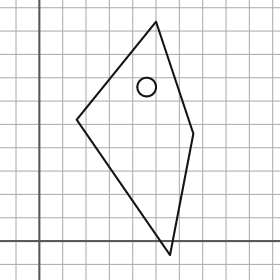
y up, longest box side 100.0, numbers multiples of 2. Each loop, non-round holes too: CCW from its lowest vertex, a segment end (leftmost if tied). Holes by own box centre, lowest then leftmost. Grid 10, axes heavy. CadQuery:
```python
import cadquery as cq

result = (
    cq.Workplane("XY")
    .moveTo(56.0, -6.0)
    .lineTo(66.0, 46.0)
    .lineTo(50.0, 94.0)
    .lineTo(16.0, 52.0)
    .close()
    .moveTo(46.0, 66.0)
    .circle(4.0)
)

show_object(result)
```